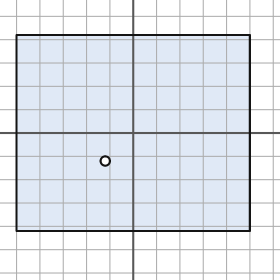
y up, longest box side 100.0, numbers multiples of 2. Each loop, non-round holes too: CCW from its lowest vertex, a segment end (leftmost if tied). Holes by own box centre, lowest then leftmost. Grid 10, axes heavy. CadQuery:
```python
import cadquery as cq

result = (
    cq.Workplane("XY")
    .moveTo(-50.0, -42.0)
    .lineTo(50.0, -42.0)
    .lineTo(50.0, 42.0)
    .lineTo(-50.0, 42.0)
    .close()
    .moveTo(-12.0, -12.0)
    .circle(2.0)
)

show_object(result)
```